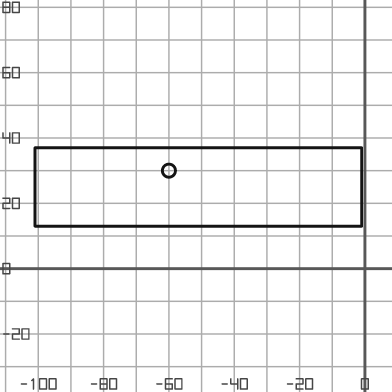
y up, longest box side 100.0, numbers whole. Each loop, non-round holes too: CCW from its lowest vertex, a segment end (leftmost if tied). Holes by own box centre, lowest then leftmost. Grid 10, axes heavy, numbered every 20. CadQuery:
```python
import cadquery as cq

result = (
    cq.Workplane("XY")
    .moveTo(-101.0, 13.0)
    .lineTo(-1.0, 13.0)
    .lineTo(-1.0, 37.0)
    .lineTo(-101.0, 37.0)
    .close()
    .moveTo(-60.0, 30.0)
    .circle(2.0)
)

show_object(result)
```